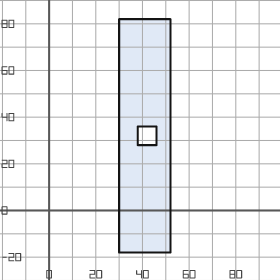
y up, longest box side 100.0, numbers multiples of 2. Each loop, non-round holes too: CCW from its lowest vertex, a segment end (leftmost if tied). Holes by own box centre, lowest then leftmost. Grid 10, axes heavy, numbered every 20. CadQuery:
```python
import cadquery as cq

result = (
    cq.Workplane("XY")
    .moveTo(30.0, -18.0)
    .lineTo(52.0, -18.0)
    .lineTo(52.0, 82.0)
    .lineTo(30.0, 82.0)
    .close()
    .moveTo(38.0, 28.0)
    .lineTo(46.0, 28.0)
    .lineTo(46.0, 36.0)
    .lineTo(38.0, 36.0)
    .close()
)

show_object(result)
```